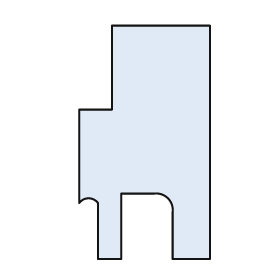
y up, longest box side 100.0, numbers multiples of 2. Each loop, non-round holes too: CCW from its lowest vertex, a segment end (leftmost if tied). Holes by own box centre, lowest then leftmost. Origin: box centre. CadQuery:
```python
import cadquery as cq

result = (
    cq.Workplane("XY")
    .moveTo(-20.0, -50.0)
    .lineTo(-10.0, -50.0)
    .lineTo(-10.0, -22.0)
    .lineTo(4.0, -22.0)
    .threePointArc((10.0, -24.0), (12.0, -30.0))
    .lineTo(12.0, -50.0)
    .lineTo(28.0, -50.0)
    .lineTo(28.0, 50.0)
    .lineTo(-14.0, 50.0)
    .lineTo(-14.0, 14.0)
    .lineTo(-28.0, 14.0)
    .lineTo(-28.0, -26.0)
    .threePointArc((-24.0, -24.0), (-20.0, -26.0))
    .close()
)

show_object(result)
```